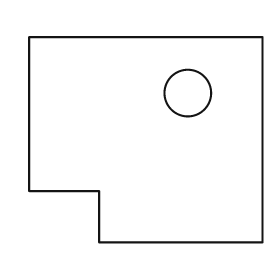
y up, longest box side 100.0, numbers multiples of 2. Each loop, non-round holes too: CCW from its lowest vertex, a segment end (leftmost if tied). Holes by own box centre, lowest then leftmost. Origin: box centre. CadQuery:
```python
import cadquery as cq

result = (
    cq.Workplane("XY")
    .moveTo(-20.0, -44.0)
    .lineTo(50.0, -44.0)
    .lineTo(50.0, 44.0)
    .lineTo(-50.0, 44.0)
    .lineTo(-50.0, -22.0)
    .lineTo(-20.0, -22.0)
    .close()
    .moveTo(18.0, 20.0)
    .circle(10.0)
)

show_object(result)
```